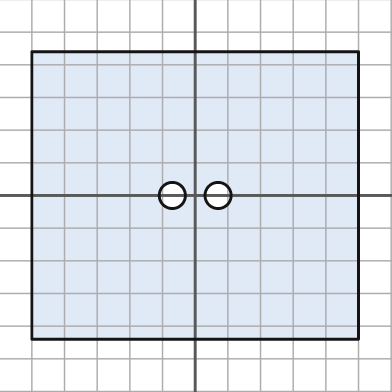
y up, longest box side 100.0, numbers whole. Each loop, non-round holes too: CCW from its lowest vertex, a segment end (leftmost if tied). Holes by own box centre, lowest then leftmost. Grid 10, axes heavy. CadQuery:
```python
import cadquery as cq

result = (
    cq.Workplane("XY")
    .moveTo(-50.0, -44.0)
    .lineTo(50.0, -44.0)
    .lineTo(50.0, 44.0)
    .lineTo(-50.0, 44.0)
    .close()
    .moveTo(-7.0, 0.0)
    .circle(4.0)
    .moveTo(7.0, 0.0)
    .circle(4.0)
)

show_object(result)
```